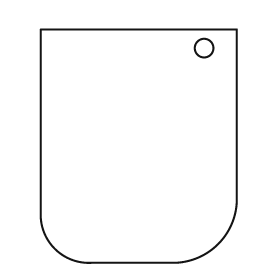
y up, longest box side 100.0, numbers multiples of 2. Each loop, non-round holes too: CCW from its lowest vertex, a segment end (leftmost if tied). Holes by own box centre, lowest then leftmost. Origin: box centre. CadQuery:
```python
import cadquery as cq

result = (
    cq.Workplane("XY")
    .moveTo(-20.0, -50.0)
    .lineTo(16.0, -50.0)
    .threePointArc((34.0, -42.0), (42.0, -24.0))
    .lineTo(42.0, 50.0)
    .lineTo(-42.0, 50.0)
    .lineTo(-42.0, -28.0)
    .threePointArc((-36.0, -44.0), (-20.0, -50.0))
    .close()
    .moveTo(28.0, 42.0)
    .circle(4.0)
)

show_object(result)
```